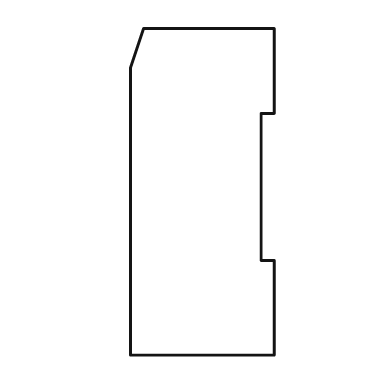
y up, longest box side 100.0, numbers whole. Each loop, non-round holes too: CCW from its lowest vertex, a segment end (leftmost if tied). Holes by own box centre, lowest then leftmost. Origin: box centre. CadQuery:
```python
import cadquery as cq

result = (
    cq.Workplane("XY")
    .moveTo(-22.0, -50.0)
    .lineTo(22.0, -50.0)
    .lineTo(22.0, -21.0)
    .lineTo(18.0, -21.0)
    .lineTo(18.0, 24.0)
    .lineTo(22.0, 24.0)
    .lineTo(22.0, 50.0)
    .lineTo(-18.0, 50.0)
    .lineTo(-22.0, 38.0)
    .close()
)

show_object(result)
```